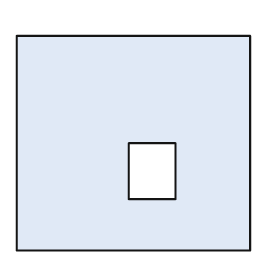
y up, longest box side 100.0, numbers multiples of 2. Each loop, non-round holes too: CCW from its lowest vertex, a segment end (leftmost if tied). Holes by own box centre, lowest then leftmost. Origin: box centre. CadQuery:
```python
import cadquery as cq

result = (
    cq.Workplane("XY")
    .moveTo(-50.0, -46.0)
    .lineTo(50.0, -46.0)
    .lineTo(50.0, 46.0)
    .lineTo(-50.0, 46.0)
    .close()
    .moveTo(-2.0, -24.0)
    .lineTo(18.0, -24.0)
    .lineTo(18.0, 0.0)
    .lineTo(-2.0, 0.0)
    .close()
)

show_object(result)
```